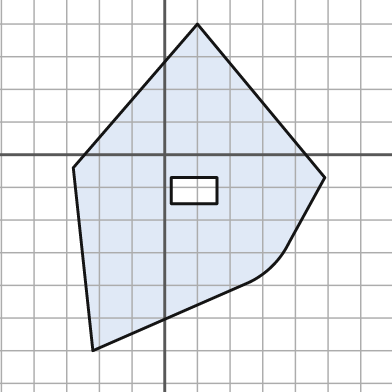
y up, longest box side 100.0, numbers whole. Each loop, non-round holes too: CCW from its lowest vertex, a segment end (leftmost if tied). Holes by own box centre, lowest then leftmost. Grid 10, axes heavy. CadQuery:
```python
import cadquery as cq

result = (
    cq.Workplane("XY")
    .moveTo(-22.0, -60.0)
    .lineTo(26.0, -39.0)
    .threePointArc((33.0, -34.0), (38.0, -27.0))
    .lineTo(49.0, -7.0)
    .lineTo(10.0, 40.0)
    .lineTo(-28.0, -4.0)
    .close()
    .moveTo(2.0, -15.0)
    .lineTo(16.0, -15.0)
    .lineTo(16.0, -7.0)
    .lineTo(2.0, -7.0)
    .close()
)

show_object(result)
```